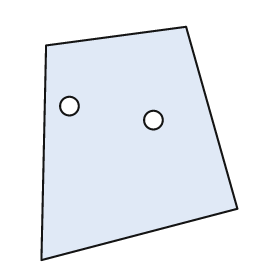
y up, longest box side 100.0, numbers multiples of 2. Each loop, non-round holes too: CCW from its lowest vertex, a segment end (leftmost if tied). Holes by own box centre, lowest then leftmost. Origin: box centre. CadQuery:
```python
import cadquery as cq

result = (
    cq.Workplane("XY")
    .moveTo(-42.0, -50.0)
    .lineTo(42.0, -28.0)
    .lineTo(20.0, 50.0)
    .lineTo(-40.0, 42.0)
    .close()
    .moveTo(6.0, 10.0)
    .circle(4.0)
    .moveTo(-30.0, 16.0)
    .circle(4.0)
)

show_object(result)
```